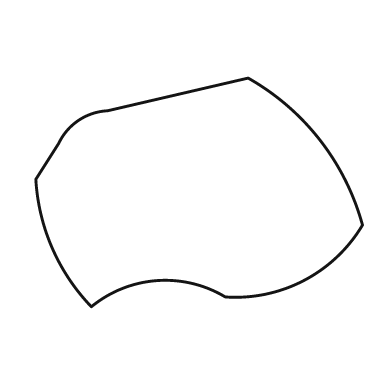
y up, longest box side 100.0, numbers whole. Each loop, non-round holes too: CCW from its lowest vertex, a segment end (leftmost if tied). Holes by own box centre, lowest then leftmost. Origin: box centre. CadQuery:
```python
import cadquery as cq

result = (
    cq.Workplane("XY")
    .moveTo(-33.0, -35.0)
    .threePointArc((-13.0, -27.0), (8.0, -32.0))
    .threePointArc((32.0, -27.0), (50.0, -10.0))
    .threePointArc((37.0, 16.0), (15.0, 35.0))
    .lineTo(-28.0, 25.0)
    .threePointArc((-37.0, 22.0), (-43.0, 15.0))
    .lineTo(-50.0, 4.0)
    .threePointArc((-45.0, -17.0), (-33.0, -35.0))
    .close()
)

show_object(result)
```